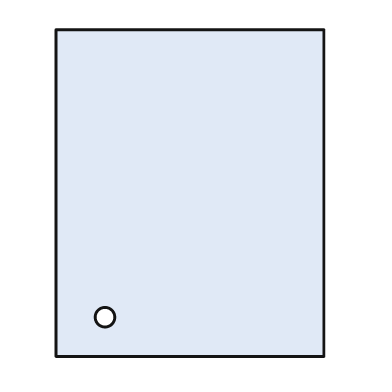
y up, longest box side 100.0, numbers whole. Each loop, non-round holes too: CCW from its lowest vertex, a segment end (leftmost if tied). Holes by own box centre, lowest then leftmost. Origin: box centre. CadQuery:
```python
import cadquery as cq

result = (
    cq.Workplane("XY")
    .moveTo(-41.0, -50.0)
    .lineTo(41.0, -50.0)
    .lineTo(41.0, 50.0)
    .lineTo(-41.0, 50.0)
    .close()
    .moveTo(-26.0, -38.0)
    .circle(3.0)
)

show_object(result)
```